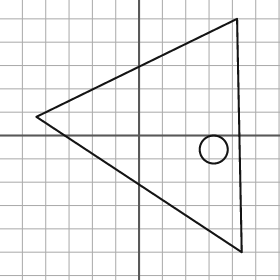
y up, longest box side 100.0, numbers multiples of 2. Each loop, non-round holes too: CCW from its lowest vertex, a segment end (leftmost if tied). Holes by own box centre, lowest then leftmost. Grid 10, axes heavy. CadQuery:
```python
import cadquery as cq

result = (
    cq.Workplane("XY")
    .moveTo(44.0, -50.0)
    .lineTo(42.0, 50.0)
    .lineTo(-44.0, 8.0)
    .close()
    .moveTo(32.0, -6.0)
    .circle(6.0)
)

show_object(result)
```